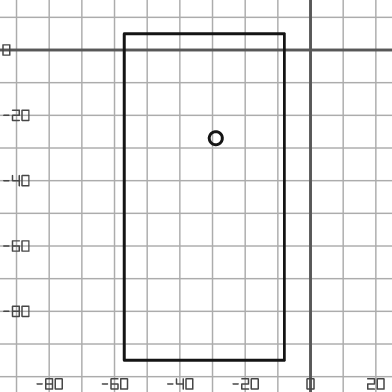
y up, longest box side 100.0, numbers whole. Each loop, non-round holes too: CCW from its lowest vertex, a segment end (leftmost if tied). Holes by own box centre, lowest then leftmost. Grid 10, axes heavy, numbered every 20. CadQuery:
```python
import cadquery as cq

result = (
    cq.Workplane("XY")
    .moveTo(-57.0, -95.0)
    .lineTo(-8.0, -95.0)
    .lineTo(-8.0, 5.0)
    .lineTo(-57.0, 5.0)
    .close()
    .moveTo(-29.0, -27.0)
    .circle(2.0)
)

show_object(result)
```